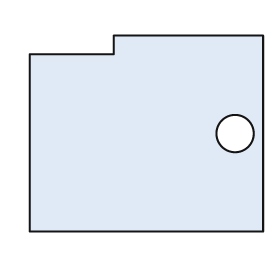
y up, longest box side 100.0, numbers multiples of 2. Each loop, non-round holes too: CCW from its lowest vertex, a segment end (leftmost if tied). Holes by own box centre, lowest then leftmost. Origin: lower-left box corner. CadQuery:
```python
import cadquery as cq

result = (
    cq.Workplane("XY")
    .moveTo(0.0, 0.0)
    .lineTo(100.0, 0.0)
    .lineTo(100.0, 84.0)
    .lineTo(36.0, 84.0)
    .lineTo(36.0, 76.0)
    .lineTo(0.0, 76.0)
    .close()
    .moveTo(88.0, 42.0)
    .circle(8.0)
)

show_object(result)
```